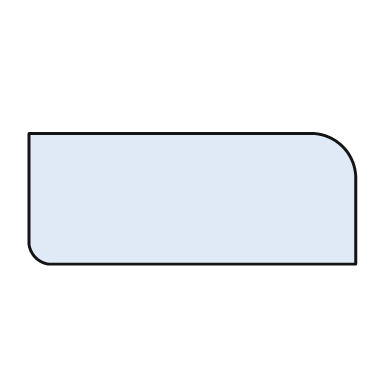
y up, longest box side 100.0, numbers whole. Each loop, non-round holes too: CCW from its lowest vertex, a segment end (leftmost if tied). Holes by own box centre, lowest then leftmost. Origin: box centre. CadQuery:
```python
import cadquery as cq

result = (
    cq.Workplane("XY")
    .moveTo(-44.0, -20.0)
    .lineTo(50.0, -20.0)
    .lineTo(50.0, 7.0)
    .threePointArc((46.0, 16.0), (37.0, 20.0))
    .lineTo(-50.0, 20.0)
    .lineTo(-50.0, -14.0)
    .threePointArc((-48.0, -18.0), (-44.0, -20.0))
    .close()
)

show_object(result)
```